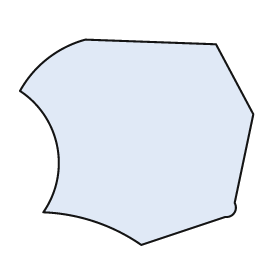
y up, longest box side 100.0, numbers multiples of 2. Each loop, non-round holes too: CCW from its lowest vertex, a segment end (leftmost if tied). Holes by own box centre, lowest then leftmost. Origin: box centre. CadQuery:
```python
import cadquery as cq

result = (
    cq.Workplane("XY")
    .moveTo(2.0, -44.0)
    .lineTo(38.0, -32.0)
    .threePointArc((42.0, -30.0), (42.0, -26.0))
    .lineTo(50.0, 12.0)
    .lineTo(34.0, 42.0)
    .lineTo(-22.0, 44.0)
    .threePointArc((-38.0, 36.0), (-50.0, 22.0))
    .threePointArc((-34.0, -2.0), (-40.0, -30.0))
    .threePointArc((-18.0, -34.0), (2.0, -44.0))
    .close()
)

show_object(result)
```